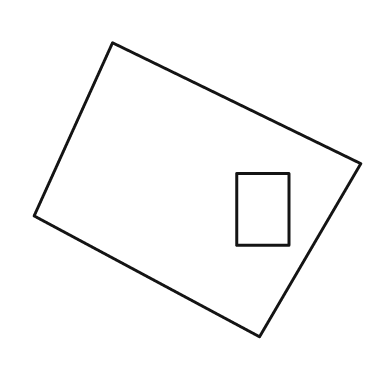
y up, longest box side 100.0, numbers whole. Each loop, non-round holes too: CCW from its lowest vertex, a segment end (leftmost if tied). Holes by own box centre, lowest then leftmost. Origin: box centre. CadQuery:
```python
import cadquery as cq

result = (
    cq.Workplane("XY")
    .moveTo(19.0, -45.0)
    .lineTo(50.0, 8.0)
    .lineTo(-26.0, 45.0)
    .lineTo(-50.0, -8.0)
    .close()
    .moveTo(12.0, -17.0)
    .lineTo(28.0, -17.0)
    .lineTo(28.0, 5.0)
    .lineTo(12.0, 5.0)
    .close()
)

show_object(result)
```